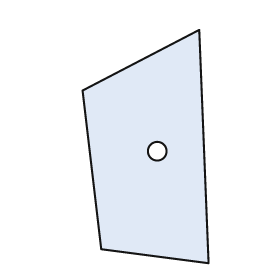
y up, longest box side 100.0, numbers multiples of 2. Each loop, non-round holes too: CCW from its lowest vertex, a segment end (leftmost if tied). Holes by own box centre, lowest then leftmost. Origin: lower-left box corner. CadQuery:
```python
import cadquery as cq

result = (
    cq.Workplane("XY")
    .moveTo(54.0, 0.0)
    .lineTo(50.0, 100.0)
    .lineTo(0.0, 74.0)
    .lineTo(8.0, 6.0)
    .close()
    .moveTo(32.0, 48.0)
    .circle(4.0)
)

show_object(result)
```